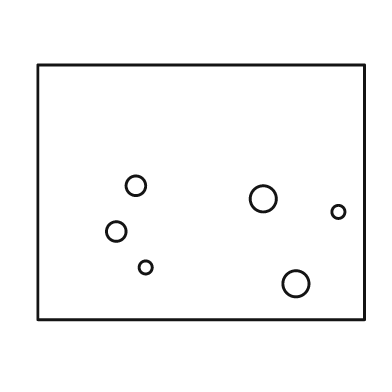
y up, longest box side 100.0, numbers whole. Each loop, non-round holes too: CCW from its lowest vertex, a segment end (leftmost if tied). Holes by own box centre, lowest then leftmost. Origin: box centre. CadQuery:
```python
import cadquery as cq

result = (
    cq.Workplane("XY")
    .moveTo(-50.0, -39.0)
    .lineTo(50.0, -39.0)
    .lineTo(50.0, 39.0)
    .lineTo(-50.0, 39.0)
    .close()
    .moveTo(29.0, -28.0)
    .circle(4.0)
    .moveTo(-17.0, -23.0)
    .circle(2.0)
    .moveTo(-26.0, -12.0)
    .circle(3.0)
    .moveTo(42.0, -6.0)
    .circle(2.0)
    .moveTo(19.0, -2.0)
    .circle(4.0)
    .moveTo(-20.0, 2.0)
    .circle(3.0)
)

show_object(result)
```